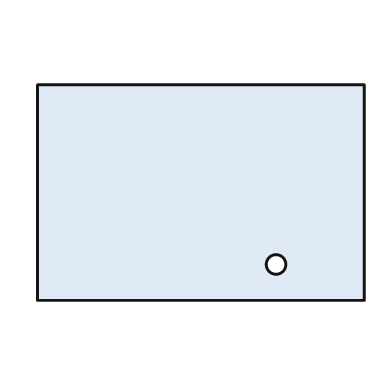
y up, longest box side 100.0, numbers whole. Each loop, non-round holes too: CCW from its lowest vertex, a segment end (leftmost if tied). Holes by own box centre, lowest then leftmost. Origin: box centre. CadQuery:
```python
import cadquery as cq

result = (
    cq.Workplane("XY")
    .moveTo(-50.0, -33.0)
    .lineTo(50.0, -33.0)
    .lineTo(50.0, 33.0)
    .lineTo(-50.0, 33.0)
    .close()
    .moveTo(23.0, -22.0)
    .circle(3.0)
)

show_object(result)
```